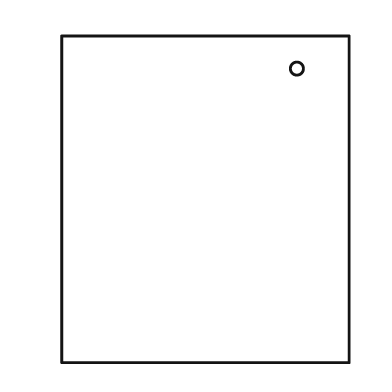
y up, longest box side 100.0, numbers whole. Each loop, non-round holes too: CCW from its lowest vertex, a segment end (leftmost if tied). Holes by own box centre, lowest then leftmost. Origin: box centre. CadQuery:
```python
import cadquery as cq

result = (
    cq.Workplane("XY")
    .moveTo(-44.0, -50.0)
    .lineTo(44.0, -50.0)
    .lineTo(44.0, 50.0)
    .lineTo(-44.0, 50.0)
    .close()
    .moveTo(28.0, 40.0)
    .circle(2.0)
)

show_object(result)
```